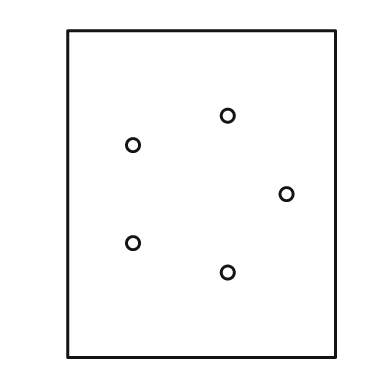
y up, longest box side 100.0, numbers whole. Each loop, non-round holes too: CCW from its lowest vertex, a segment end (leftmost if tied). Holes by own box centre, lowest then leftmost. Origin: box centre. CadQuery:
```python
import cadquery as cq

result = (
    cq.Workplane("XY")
    .moveTo(-41.0, -50.0)
    .lineTo(41.0, -50.0)
    .lineTo(41.0, 50.0)
    .lineTo(-41.0, 50.0)
    .close()
    .moveTo(8.0, -24.0)
    .circle(2.0)
    .moveTo(-21.0, -15.0)
    .circle(2.0)
    .moveTo(26.0, 0.0)
    .circle(2.0)
    .moveTo(-21.0, 15.0)
    .circle(2.0)
    .moveTo(8.0, 24.0)
    .circle(2.0)
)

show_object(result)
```